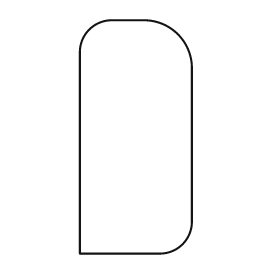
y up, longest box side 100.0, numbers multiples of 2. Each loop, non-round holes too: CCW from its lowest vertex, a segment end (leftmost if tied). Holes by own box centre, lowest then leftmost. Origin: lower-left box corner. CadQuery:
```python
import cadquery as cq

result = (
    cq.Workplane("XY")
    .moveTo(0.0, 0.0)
    .lineTo(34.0, 0.0)
    .threePointArc((44.0, 4.0), (48.0, 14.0))
    .lineTo(48.0, 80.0)
    .threePointArc((42.0, 94.0), (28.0, 100.0))
    .lineTo(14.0, 100.0)
    .threePointArc((4.0, 96.0), (0.0, 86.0))
    .close()
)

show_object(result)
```